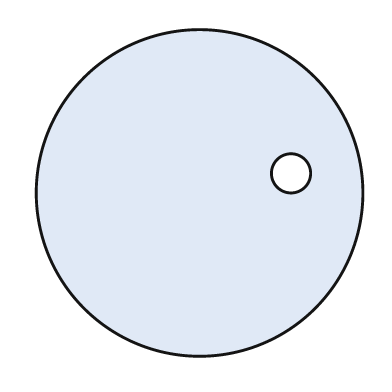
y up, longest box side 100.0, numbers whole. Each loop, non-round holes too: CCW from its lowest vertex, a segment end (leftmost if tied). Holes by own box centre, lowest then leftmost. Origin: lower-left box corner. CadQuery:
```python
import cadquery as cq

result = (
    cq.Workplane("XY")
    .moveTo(50.0, 50.0)
    .circle(50.0)
    .moveTo(78.0, 56.0)
    .circle(6.0)
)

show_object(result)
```